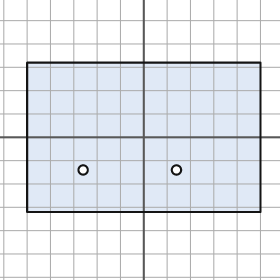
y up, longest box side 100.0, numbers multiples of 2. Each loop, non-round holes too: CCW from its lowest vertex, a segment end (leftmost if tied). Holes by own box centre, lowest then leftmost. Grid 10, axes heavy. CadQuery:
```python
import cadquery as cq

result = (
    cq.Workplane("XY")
    .moveTo(-50.0, -32.0)
    .lineTo(50.0, -32.0)
    .lineTo(50.0, 32.0)
    .lineTo(-50.0, 32.0)
    .close()
    .moveTo(-26.0, -14.0)
    .circle(2.0)
    .moveTo(14.0, -14.0)
    .circle(2.0)
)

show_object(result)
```